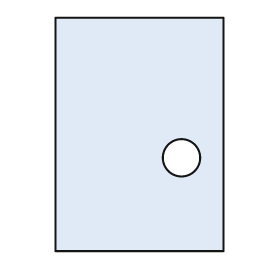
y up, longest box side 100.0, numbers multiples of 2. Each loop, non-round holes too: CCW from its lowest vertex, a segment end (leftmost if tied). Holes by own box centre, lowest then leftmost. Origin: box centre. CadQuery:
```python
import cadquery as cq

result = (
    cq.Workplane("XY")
    .moveTo(-36.0, -50.0)
    .lineTo(36.0, -50.0)
    .lineTo(36.0, 50.0)
    .lineTo(-36.0, 50.0)
    .close()
    .moveTo(18.0, -10.0)
    .circle(8.0)
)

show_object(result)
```